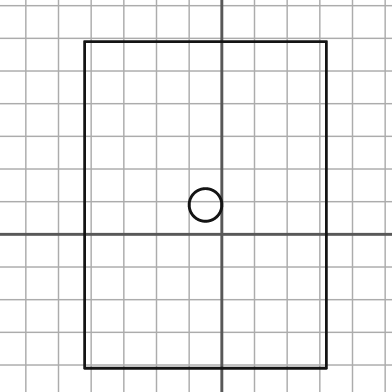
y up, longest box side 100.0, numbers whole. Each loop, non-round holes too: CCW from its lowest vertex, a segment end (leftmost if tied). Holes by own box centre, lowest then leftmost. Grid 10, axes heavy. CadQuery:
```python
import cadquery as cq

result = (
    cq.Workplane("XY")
    .moveTo(-42.0, -41.0)
    .lineTo(32.0, -41.0)
    .lineTo(32.0, 59.0)
    .lineTo(-42.0, 59.0)
    .close()
    .moveTo(-5.0, 9.0)
    .circle(5.0)
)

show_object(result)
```